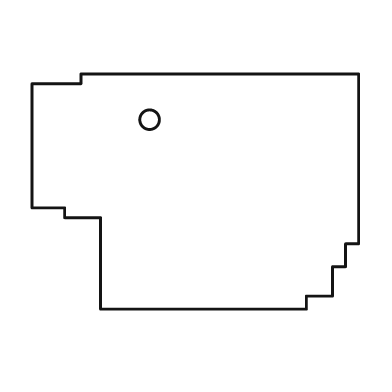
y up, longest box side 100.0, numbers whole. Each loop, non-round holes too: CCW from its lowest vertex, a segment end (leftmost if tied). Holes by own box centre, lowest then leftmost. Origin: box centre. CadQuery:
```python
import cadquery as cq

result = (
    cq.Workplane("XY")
    .moveTo(-29.0, -36.0)
    .lineTo(34.0, -36.0)
    .lineTo(34.0, -32.0)
    .lineTo(42.0, -32.0)
    .lineTo(42.0, -23.0)
    .lineTo(46.0, -23.0)
    .lineTo(46.0, -16.0)
    .lineTo(50.0, -16.0)
    .lineTo(50.0, 36.0)
    .lineTo(-35.0, 36.0)
    .lineTo(-35.0, 33.0)
    .lineTo(-50.0, 33.0)
    .lineTo(-50.0, -5.0)
    .lineTo(-40.0, -5.0)
    .lineTo(-40.0, -8.0)
    .lineTo(-29.0, -8.0)
    .close()
    .moveTo(-14.0, 22.0)
    .circle(3.0)
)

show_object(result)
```